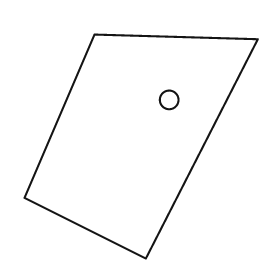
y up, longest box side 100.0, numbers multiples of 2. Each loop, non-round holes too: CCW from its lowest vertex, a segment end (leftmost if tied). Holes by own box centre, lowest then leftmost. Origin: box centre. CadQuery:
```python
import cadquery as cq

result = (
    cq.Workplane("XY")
    .moveTo(2.0, -48.0)
    .lineTo(50.0, 46.0)
    .lineTo(-20.0, 48.0)
    .lineTo(-50.0, -22.0)
    .close()
    .moveTo(12.0, 20.0)
    .circle(4.0)
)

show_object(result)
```